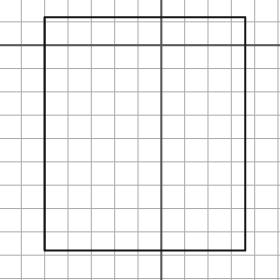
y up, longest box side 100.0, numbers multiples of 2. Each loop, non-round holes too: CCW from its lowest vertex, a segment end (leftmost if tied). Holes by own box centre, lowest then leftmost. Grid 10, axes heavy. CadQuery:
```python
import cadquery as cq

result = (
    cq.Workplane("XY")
    .moveTo(-50.0, -88.0)
    .lineTo(36.0, -88.0)
    .lineTo(36.0, 12.0)
    .lineTo(-50.0, 12.0)
    .close()
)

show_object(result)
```